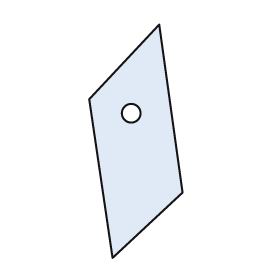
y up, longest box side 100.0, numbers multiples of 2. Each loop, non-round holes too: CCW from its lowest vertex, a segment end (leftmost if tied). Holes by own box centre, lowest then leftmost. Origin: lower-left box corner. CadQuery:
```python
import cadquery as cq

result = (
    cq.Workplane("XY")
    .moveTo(10.0, 0.0)
    .lineTo(40.0, 28.0)
    .lineTo(30.0, 100.0)
    .lineTo(0.0, 68.0)
    .close()
    .moveTo(18.0, 62.0)
    .circle(4.0)
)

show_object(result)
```